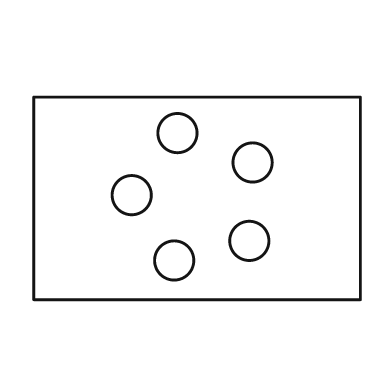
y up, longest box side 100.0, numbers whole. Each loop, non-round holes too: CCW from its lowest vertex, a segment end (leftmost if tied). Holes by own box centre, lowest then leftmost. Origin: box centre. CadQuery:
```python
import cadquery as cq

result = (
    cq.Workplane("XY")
    .moveTo(-50.0, -31.0)
    .lineTo(50.0, -31.0)
    .lineTo(50.0, 31.0)
    .lineTo(-50.0, 31.0)
    .close()
    .moveTo(-7.0, -19.0)
    .circle(6.0)
    .moveTo(16.0, -13.0)
    .circle(6.0)
    .moveTo(-20.0, 1.0)
    .circle(6.0)
    .moveTo(17.0, 11.0)
    .circle(6.0)
    .moveTo(-6.0, 20.0)
    .circle(6.0)
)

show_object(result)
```